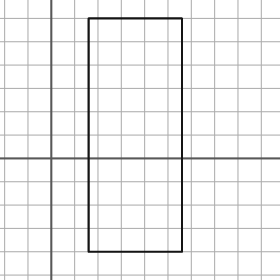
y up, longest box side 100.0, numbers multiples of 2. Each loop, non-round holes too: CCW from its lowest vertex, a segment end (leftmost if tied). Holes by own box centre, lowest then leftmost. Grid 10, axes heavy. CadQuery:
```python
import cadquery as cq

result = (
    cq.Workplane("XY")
    .moveTo(16.0, -40.0)
    .lineTo(56.0, -40.0)
    .lineTo(56.0, 60.0)
    .lineTo(16.0, 60.0)
    .close()
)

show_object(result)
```